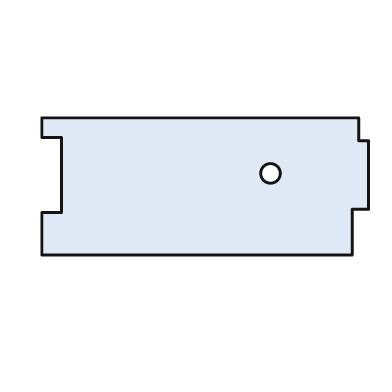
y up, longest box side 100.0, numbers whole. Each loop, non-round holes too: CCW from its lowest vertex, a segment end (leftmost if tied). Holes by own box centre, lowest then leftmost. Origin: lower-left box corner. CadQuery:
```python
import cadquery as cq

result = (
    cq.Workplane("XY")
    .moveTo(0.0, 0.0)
    .lineTo(95.0, 0.0)
    .lineTo(95.0, 14.0)
    .lineTo(100.0, 14.0)
    .lineTo(100.0, 35.0)
    .lineTo(97.0, 35.0)
    .lineTo(97.0, 42.0)
    .lineTo(0.0, 42.0)
    .lineTo(0.0, 36.0)
    .lineTo(6.0, 36.0)
    .lineTo(6.0, 13.0)
    .lineTo(0.0, 13.0)
    .close()
    .moveTo(70.0, 25.0)
    .circle(3.0)
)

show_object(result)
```